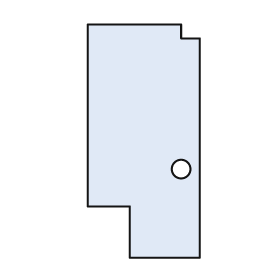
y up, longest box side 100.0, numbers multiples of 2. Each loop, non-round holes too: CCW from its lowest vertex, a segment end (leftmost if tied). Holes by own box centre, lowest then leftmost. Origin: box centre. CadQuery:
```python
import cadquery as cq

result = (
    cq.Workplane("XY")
    .moveTo(-6.0, -50.0)
    .lineTo(24.0, -50.0)
    .lineTo(24.0, 44.0)
    .lineTo(16.0, 44.0)
    .lineTo(16.0, 50.0)
    .lineTo(-24.0, 50.0)
    .lineTo(-24.0, -28.0)
    .lineTo(-6.0, -28.0)
    .close()
    .moveTo(16.0, -12.0)
    .circle(4.0)
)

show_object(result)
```